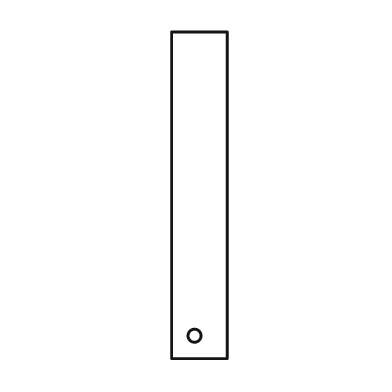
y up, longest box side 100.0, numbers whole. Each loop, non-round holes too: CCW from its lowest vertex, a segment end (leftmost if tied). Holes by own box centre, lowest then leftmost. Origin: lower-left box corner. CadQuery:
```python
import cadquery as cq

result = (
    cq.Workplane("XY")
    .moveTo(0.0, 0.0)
    .lineTo(17.0, 0.0)
    .lineTo(17.0, 100.0)
    .lineTo(0.0, 100.0)
    .close()
    .moveTo(7.0, 7.0)
    .circle(2.0)
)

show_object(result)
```